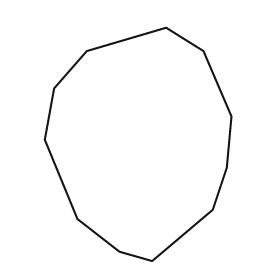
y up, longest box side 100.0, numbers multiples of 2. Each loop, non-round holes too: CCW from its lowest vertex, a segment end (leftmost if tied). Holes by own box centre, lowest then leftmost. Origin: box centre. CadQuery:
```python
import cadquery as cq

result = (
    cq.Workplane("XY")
    .moveTo(6.0, -50.0)
    .lineTo(32.0, -28.0)
    .lineTo(38.0, -10.0)
    .lineTo(40.0, 12.0)
    .lineTo(28.0, 40.0)
    .lineTo(12.0, 50.0)
    .lineTo(-22.0, 40.0)
    .lineTo(-36.0, 24.0)
    .lineTo(-40.0, 2.0)
    .lineTo(-26.0, -32.0)
    .lineTo(-8.0, -46.0)
    .close()
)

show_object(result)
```